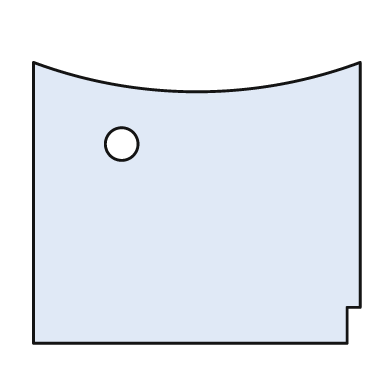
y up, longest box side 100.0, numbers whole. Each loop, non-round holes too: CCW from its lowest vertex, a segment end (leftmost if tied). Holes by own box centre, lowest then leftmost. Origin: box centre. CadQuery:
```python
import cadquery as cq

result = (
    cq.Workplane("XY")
    .moveTo(-50.0, -43.0)
    .lineTo(46.0, -43.0)
    .lineTo(46.0, -32.0)
    .lineTo(50.0, -32.0)
    .lineTo(50.0, 43.0)
    .threePointArc((0.0, 34.0), (-50.0, 43.0))
    .close()
    .moveTo(-23.0, 18.0)
    .circle(5.0)
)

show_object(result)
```